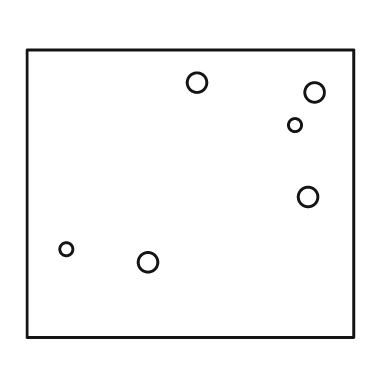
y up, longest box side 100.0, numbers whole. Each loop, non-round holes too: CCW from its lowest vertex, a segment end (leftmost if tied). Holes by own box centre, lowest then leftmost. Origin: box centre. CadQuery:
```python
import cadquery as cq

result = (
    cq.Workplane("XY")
    .moveTo(-50.0, -44.0)
    .lineTo(50.0, -44.0)
    .lineTo(50.0, 44.0)
    .lineTo(-50.0, 44.0)
    .close()
    .moveTo(-13.0, -21.0)
    .circle(3.0)
    .moveTo(-38.0, -17.0)
    .circle(2.0)
    .moveTo(36.0, -1.0)
    .circle(3.0)
    .moveTo(32.0, 21.0)
    .circle(2.0)
    .moveTo(38.0, 31.0)
    .circle(3.0)
    .moveTo(2.0, 34.0)
    .circle(3.0)
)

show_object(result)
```